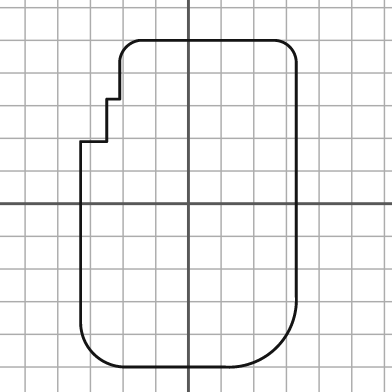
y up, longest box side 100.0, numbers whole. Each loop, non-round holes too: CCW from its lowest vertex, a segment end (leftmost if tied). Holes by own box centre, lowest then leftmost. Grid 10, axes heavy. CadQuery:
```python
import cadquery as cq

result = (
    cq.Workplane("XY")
    .moveTo(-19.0, -50.0)
    .lineTo(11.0, -50.0)
    .threePointArc((27.0, -44.0), (33.0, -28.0))
    .lineTo(33.0, 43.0)
    .threePointArc((31.0, 48.0), (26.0, 50.0))
    .lineTo(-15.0, 50.0)
    .threePointArc((-19.0, 48.0), (-21.0, 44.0))
    .lineTo(-21.0, 32.0)
    .lineTo(-25.0, 32.0)
    .lineTo(-25.0, 19.0)
    .lineTo(-33.0, 19.0)
    .lineTo(-33.0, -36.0)
    .threePointArc((-29.0, -46.0), (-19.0, -50.0))
    .close()
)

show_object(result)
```